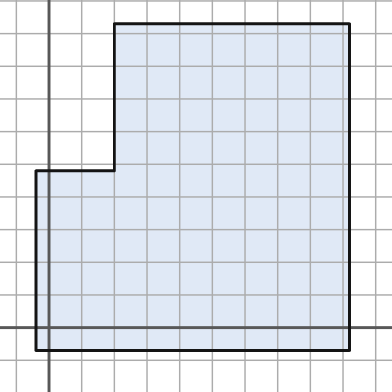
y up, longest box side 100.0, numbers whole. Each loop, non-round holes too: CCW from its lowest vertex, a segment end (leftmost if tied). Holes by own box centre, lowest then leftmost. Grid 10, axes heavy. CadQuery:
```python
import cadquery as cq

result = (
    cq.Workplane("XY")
    .moveTo(-4.0, -7.0)
    .lineTo(92.0, -7.0)
    .lineTo(92.0, 93.0)
    .lineTo(20.0, 93.0)
    .lineTo(20.0, 48.0)
    .lineTo(-4.0, 48.0)
    .close()
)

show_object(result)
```